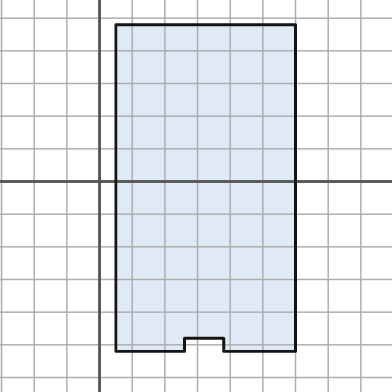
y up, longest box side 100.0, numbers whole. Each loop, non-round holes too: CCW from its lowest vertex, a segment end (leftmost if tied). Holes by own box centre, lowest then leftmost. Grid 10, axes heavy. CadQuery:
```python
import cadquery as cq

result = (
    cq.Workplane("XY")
    .moveTo(5.0, -52.0)
    .lineTo(26.0, -52.0)
    .lineTo(26.0, -48.0)
    .lineTo(38.0, -48.0)
    .lineTo(38.0, -52.0)
    .lineTo(60.0, -52.0)
    .lineTo(60.0, 48.0)
    .lineTo(5.0, 48.0)
    .close()
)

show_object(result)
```